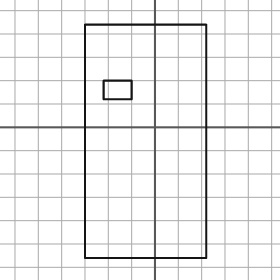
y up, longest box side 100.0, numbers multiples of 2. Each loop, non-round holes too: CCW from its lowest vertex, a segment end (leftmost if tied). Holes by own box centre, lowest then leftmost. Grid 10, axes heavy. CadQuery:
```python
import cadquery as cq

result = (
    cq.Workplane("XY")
    .moveTo(-30.0, -56.0)
    .lineTo(22.0, -56.0)
    .lineTo(22.0, 44.0)
    .lineTo(-30.0, 44.0)
    .close()
    .moveTo(-22.0, 12.0)
    .lineTo(-10.0, 12.0)
    .lineTo(-10.0, 20.0)
    .lineTo(-22.0, 20.0)
    .close()
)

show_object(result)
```